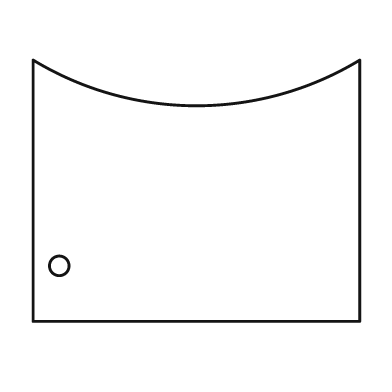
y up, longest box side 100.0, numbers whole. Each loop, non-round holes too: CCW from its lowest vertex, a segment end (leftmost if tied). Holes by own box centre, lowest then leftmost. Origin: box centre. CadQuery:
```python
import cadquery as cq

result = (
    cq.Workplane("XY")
    .moveTo(-50.0, -40.0)
    .lineTo(50.0, -40.0)
    .lineTo(50.0, 40.0)
    .threePointArc((0.0, 26.0), (-50.0, 40.0))
    .close()
    .moveTo(-42.0, -23.0)
    .circle(3.0)
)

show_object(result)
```